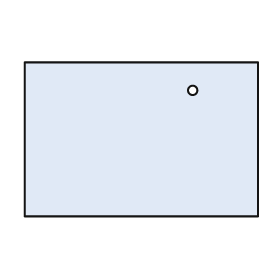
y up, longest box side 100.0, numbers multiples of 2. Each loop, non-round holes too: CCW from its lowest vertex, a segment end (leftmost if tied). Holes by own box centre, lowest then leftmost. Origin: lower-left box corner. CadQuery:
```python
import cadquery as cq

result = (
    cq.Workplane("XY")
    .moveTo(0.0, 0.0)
    .lineTo(100.0, 0.0)
    .lineTo(100.0, 66.0)
    .lineTo(0.0, 66.0)
    .close()
    .moveTo(72.0, 54.0)
    .circle(2.0)
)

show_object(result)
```